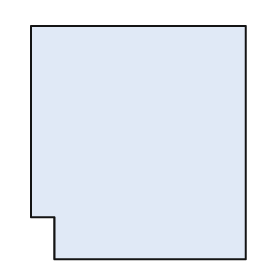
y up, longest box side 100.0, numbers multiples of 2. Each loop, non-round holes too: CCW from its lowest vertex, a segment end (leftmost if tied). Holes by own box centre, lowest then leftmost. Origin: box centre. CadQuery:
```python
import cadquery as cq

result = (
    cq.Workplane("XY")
    .moveTo(-36.0, -50.0)
    .lineTo(46.0, -50.0)
    .lineTo(46.0, 50.0)
    .lineTo(-46.0, 50.0)
    .lineTo(-46.0, -32.0)
    .lineTo(-36.0, -32.0)
    .close()
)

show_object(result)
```